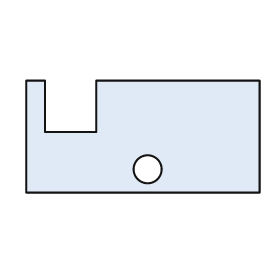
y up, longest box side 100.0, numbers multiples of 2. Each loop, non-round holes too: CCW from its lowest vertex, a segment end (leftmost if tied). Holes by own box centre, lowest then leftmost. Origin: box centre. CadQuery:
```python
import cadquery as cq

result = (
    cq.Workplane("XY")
    .moveTo(-50.0, -24.0)
    .lineTo(50.0, -24.0)
    .lineTo(50.0, 24.0)
    .lineTo(-20.0, 24.0)
    .lineTo(-20.0, 2.0)
    .lineTo(-42.0, 2.0)
    .lineTo(-42.0, 24.0)
    .lineTo(-50.0, 24.0)
    .close()
    .moveTo(2.0, -14.0)
    .circle(6.0)
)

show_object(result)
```